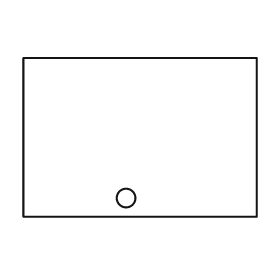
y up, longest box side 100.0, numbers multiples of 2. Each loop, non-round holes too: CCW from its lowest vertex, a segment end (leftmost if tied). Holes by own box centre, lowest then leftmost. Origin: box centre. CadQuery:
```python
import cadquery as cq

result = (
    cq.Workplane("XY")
    .moveTo(-50.0, -34.0)
    .lineTo(50.0, -34.0)
    .lineTo(50.0, 34.0)
    .lineTo(-50.0, 34.0)
    .close()
    .moveTo(-6.0, -26.0)
    .circle(4.0)
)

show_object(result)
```